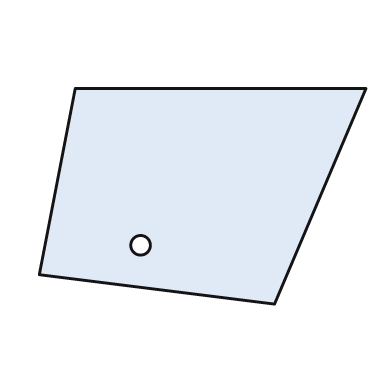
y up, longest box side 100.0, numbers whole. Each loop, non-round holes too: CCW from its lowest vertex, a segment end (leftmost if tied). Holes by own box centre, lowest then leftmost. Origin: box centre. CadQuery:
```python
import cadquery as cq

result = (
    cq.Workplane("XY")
    .moveTo(22.0, -33.0)
    .lineTo(50.0, 33.0)
    .lineTo(-39.0, 33.0)
    .lineTo(-50.0, -24.0)
    .close()
    .moveTo(-19.0, -15.0)
    .circle(3.0)
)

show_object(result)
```